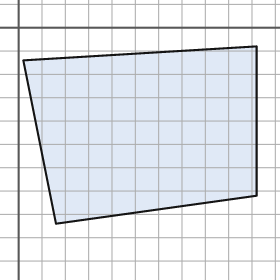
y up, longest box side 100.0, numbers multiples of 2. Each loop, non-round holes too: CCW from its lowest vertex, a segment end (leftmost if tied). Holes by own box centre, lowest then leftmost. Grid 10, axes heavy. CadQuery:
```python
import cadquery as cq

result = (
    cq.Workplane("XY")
    .moveTo(16.0, -84.0)
    .lineTo(102.0, -72.0)
    .lineTo(102.0, -8.0)
    .lineTo(2.0, -14.0)
    .close()
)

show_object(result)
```